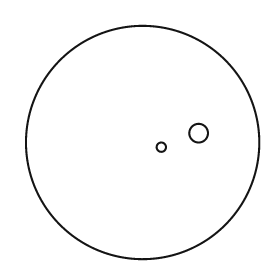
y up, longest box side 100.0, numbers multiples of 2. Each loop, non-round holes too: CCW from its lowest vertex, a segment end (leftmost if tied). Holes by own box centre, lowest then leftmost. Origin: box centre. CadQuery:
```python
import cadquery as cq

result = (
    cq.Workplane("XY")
    .moveTo(0.0, 0.0)
    .circle(50.0)
    .moveTo(8.0, -2.0)
    .circle(2.0)
    .moveTo(24.0, 4.0)
    .circle(4.0)
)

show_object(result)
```